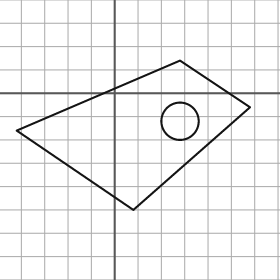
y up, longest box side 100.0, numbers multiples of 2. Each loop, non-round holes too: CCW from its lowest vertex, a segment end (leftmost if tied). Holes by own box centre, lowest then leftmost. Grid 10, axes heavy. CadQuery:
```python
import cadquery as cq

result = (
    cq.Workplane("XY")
    .moveTo(8.0, -50.0)
    .lineTo(58.0, -6.0)
    .lineTo(28.0, 14.0)
    .lineTo(-42.0, -16.0)
    .close()
    .moveTo(28.0, -12.0)
    .circle(8.0)
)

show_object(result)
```